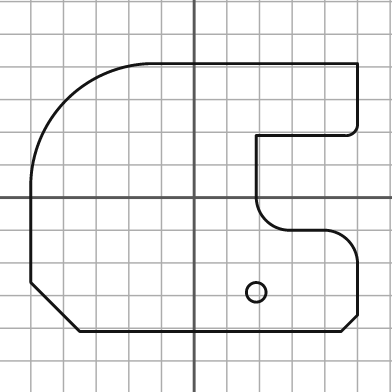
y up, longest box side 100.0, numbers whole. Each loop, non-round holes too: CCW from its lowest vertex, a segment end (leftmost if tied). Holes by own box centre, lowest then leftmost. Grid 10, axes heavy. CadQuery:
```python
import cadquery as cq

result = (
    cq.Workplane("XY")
    .moveTo(-35.0, -41.0)
    .lineTo(45.0, -41.0)
    .lineTo(50.0, -36.0)
    .lineTo(50.0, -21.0)
    .threePointArc((47.0, -13.0), (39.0, -10.0))
    .lineTo(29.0, -10.0)
    .threePointArc((22.0, -7.0), (19.0, 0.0))
    .lineTo(19.0, 19.0)
    .lineTo(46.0, 19.0)
    .threePointArc((49.0, 20.0), (50.0, 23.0))
    .lineTo(50.0, 41.0)
    .lineTo(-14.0, 41.0)
    .threePointArc((-39.0, 30.0), (-50.0, 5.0))
    .lineTo(-50.0, -26.0)
    .close()
    .moveTo(19.0, -29.0)
    .circle(3.0)
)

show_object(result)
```